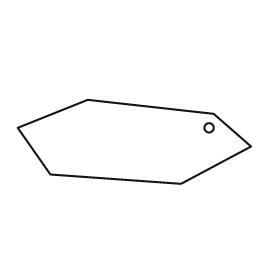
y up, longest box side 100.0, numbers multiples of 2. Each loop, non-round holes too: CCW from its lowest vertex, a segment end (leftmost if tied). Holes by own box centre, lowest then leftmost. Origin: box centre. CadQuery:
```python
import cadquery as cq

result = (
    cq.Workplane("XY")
    .moveTo(20.0, -18.0)
    .lineTo(50.0, -2.0)
    .lineTo(34.0, 12.0)
    .lineTo(-20.0, 18.0)
    .lineTo(-50.0, 6.0)
    .lineTo(-36.0, -14.0)
    .close()
    .moveTo(32.0, 6.0)
    .circle(2.0)
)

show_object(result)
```